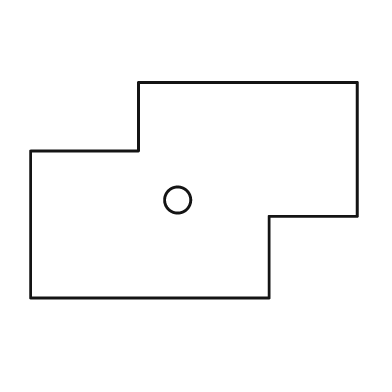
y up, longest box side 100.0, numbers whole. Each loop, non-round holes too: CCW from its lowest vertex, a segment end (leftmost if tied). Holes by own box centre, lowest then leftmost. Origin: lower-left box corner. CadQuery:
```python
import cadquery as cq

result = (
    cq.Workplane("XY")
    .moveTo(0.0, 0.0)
    .lineTo(73.0, 0.0)
    .lineTo(73.0, 25.0)
    .lineTo(100.0, 25.0)
    .lineTo(100.0, 66.0)
    .lineTo(33.0, 66.0)
    .lineTo(33.0, 45.0)
    .lineTo(0.0, 45.0)
    .close()
    .moveTo(45.0, 30.0)
    .circle(4.0)
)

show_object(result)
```